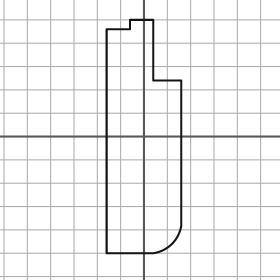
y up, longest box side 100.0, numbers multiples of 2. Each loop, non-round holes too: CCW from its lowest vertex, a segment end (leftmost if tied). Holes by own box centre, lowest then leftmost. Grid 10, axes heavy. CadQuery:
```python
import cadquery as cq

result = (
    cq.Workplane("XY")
    .moveTo(-16.0, -50.0)
    .lineTo(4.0, -50.0)
    .threePointArc((12.0, -46.0), (16.0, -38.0))
    .lineTo(16.0, 24.0)
    .lineTo(4.0, 24.0)
    .lineTo(4.0, 50.0)
    .lineTo(-6.0, 50.0)
    .lineTo(-6.0, 46.0)
    .lineTo(-16.0, 46.0)
    .close()
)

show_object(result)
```